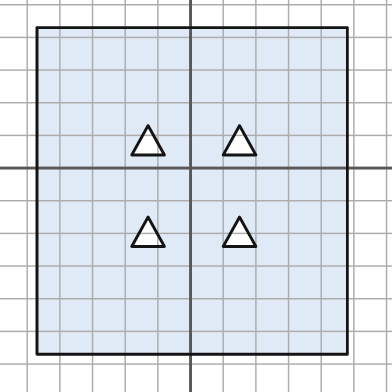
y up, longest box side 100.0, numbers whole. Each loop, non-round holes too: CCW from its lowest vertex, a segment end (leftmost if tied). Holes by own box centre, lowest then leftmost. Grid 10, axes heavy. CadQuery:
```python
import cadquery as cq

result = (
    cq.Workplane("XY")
    .moveTo(-47.0, -57.0)
    .lineTo(48.0, -57.0)
    .lineTo(48.0, 43.0)
    .lineTo(-47.0, 43.0)
    .close()
    .moveTo(-18.0, -24.0)
    .lineTo(-8.0, -24.0)
    .lineTo(-13.0, -15.0)
    .close()
    .moveTo(10.0, -24.0)
    .lineTo(20.0, -24.0)
    .lineTo(15.0, -15.0)
    .close()
    .moveTo(-18.0, 4.0)
    .lineTo(-8.0, 4.0)
    .lineTo(-13.0, 13.0)
    .close()
    .moveTo(10.0, 4.0)
    .lineTo(20.0, 4.0)
    .lineTo(15.0, 13.0)
    .close()
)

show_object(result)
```